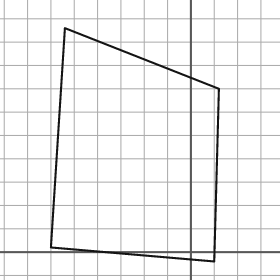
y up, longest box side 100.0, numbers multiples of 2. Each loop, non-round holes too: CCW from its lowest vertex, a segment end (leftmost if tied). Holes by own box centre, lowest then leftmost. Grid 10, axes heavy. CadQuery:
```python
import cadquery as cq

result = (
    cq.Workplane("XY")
    .moveTo(10.0, -4.0)
    .lineTo(12.0, 70.0)
    .lineTo(-54.0, 96.0)
    .lineTo(-60.0, 2.0)
    .close()
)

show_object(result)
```